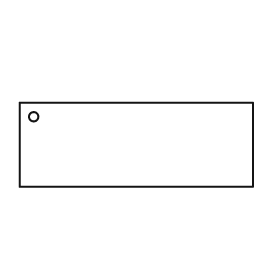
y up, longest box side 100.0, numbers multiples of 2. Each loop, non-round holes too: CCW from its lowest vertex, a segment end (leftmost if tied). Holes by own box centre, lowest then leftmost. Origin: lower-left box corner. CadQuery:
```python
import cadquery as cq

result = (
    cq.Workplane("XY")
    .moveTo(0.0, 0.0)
    .lineTo(100.0, 0.0)
    .lineTo(100.0, 36.0)
    .lineTo(0.0, 36.0)
    .close()
    .moveTo(6.0, 30.0)
    .circle(2.0)
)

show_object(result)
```